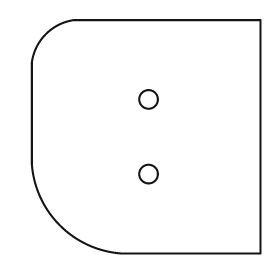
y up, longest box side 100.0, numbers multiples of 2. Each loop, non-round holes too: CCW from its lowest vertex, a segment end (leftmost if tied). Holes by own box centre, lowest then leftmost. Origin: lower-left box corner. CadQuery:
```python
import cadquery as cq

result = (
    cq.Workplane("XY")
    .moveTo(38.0, 0.0)
    .lineTo(98.0, 0.0)
    .lineTo(98.0, 100.0)
    .lineTo(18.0, 100.0)
    .threePointArc((6.0, 94.0), (0.0, 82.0))
    .lineTo(0.0, 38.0)
    .threePointArc((12.0, 12.0), (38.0, 0.0))
    .close()
    .moveTo(50.0, 34.0)
    .circle(4.0)
    .moveTo(50.0, 66.0)
    .circle(4.0)
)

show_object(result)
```